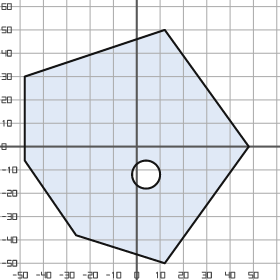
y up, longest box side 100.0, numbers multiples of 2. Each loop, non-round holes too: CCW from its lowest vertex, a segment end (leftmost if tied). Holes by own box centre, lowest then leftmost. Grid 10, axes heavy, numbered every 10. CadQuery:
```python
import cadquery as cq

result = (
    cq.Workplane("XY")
    .moveTo(12.0, -50.0)
    .lineTo(48.0, 0.0)
    .lineTo(12.0, 50.0)
    .lineTo(-48.0, 30.0)
    .lineTo(-48.0, -6.0)
    .lineTo(-26.0, -38.0)
    .close()
    .moveTo(4.0, -12.0)
    .circle(6.0)
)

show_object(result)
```